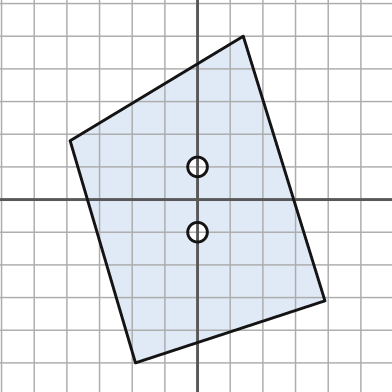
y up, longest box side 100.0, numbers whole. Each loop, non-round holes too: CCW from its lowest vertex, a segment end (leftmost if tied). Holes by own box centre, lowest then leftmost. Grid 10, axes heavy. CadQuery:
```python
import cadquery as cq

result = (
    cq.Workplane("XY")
    .moveTo(-19.0, -50.0)
    .lineTo(39.0, -31.0)
    .lineTo(14.0, 50.0)
    .lineTo(-39.0, 18.0)
    .close()
    .moveTo(0.0, -10.0)
    .circle(3.0)
    .moveTo(0.0, 10.0)
    .circle(3.0)
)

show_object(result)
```